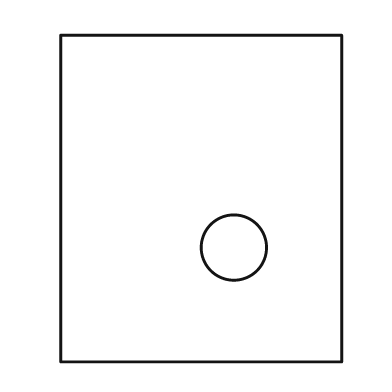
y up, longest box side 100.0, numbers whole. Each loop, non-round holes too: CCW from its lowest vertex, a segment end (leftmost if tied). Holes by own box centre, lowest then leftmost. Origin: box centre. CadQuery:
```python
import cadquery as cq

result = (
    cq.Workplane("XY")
    .moveTo(-43.0, -50.0)
    .lineTo(43.0, -50.0)
    .lineTo(43.0, 50.0)
    .lineTo(-43.0, 50.0)
    .close()
    .moveTo(10.0, -15.0)
    .circle(10.0)
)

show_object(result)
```